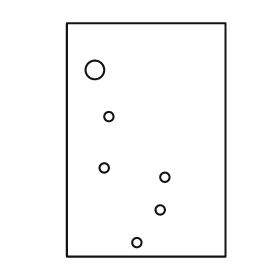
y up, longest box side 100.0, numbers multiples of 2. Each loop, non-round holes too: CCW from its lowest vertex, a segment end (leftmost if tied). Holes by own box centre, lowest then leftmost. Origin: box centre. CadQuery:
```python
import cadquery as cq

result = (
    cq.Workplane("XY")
    .moveTo(-34.0, -50.0)
    .lineTo(34.0, -50.0)
    .lineTo(34.0, 50.0)
    .lineTo(-34.0, 50.0)
    .close()
    .moveTo(-4.0, -44.0)
    .circle(2.0)
    .moveTo(6.0, -30.0)
    .circle(2.0)
    .moveTo(8.0, -16.0)
    .circle(2.0)
    .moveTo(-18.0, -12.0)
    .circle(2.0)
    .moveTo(-16.0, 10.0)
    .circle(2.0)
    .moveTo(-22.0, 30.0)
    .circle(4.0)
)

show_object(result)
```